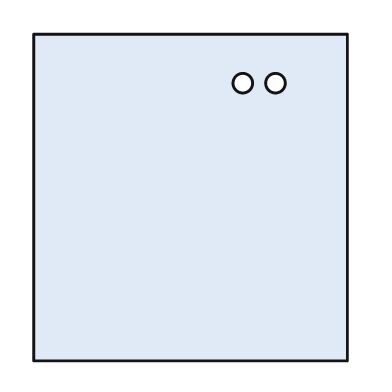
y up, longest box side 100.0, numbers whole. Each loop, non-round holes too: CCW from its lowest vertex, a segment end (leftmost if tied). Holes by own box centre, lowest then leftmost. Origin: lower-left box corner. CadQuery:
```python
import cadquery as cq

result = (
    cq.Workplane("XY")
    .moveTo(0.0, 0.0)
    .lineTo(96.0, 0.0)
    .lineTo(96.0, 100.0)
    .lineTo(0.0, 100.0)
    .close()
    .moveTo(64.0, 85.0)
    .circle(3.0)
    .moveTo(74.0, 85.0)
    .circle(3.0)
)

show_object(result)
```